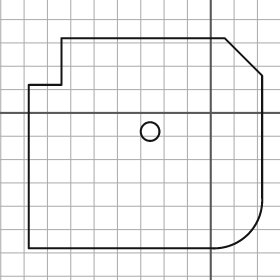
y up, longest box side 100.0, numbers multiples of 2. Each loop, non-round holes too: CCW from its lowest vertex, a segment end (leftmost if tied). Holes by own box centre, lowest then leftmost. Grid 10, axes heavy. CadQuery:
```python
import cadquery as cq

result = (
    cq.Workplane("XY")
    .moveTo(-78.0, -58.0)
    .lineTo(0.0, -58.0)
    .threePointArc((16.0, -52.0), (22.0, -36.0))
    .lineTo(22.0, 16.0)
    .lineTo(6.0, 32.0)
    .lineTo(-64.0, 32.0)
    .lineTo(-64.0, 12.0)
    .lineTo(-78.0, 12.0)
    .close()
    .moveTo(-26.0, -8.0)
    .circle(4.0)
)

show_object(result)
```